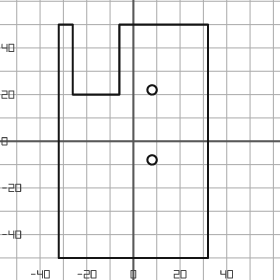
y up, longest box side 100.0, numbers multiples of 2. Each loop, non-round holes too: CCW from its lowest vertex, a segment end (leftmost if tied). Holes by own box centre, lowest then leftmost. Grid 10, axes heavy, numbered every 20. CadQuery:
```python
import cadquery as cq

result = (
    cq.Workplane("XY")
    .moveTo(-32.0, -50.0)
    .lineTo(32.0, -50.0)
    .lineTo(32.0, 50.0)
    .lineTo(-6.0, 50.0)
    .lineTo(-6.0, 20.0)
    .lineTo(-26.0, 20.0)
    .lineTo(-26.0, 50.0)
    .lineTo(-32.0, 50.0)
    .close()
    .moveTo(8.0, -8.0)
    .circle(2.0)
    .moveTo(8.0, 22.0)
    .circle(2.0)
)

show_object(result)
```